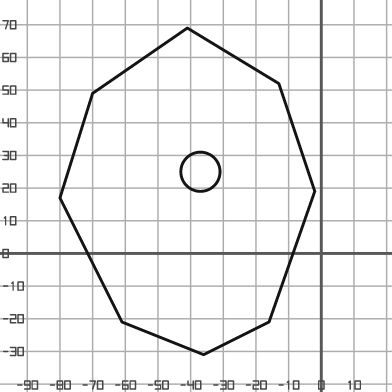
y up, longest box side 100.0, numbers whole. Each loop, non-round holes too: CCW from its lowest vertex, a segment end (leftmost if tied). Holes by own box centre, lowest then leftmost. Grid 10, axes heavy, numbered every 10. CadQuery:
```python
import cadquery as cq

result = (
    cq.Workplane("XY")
    .moveTo(-36.0, -31.0)
    .lineTo(-16.0, -21.0)
    .lineTo(-2.0, 19.0)
    .lineTo(-13.0, 52.0)
    .lineTo(-41.0, 69.0)
    .lineTo(-70.0, 49.0)
    .lineTo(-80.0, 17.0)
    .lineTo(-61.0, -21.0)
    .close()
    .moveTo(-37.0, 25.0)
    .circle(6.0)
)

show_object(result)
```